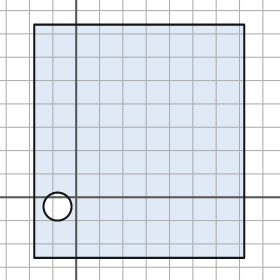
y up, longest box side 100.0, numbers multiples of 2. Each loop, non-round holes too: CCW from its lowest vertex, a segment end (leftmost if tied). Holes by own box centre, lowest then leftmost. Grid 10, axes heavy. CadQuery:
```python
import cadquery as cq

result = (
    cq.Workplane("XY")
    .moveTo(-18.0, -26.0)
    .lineTo(72.0, -26.0)
    .lineTo(72.0, 74.0)
    .lineTo(-18.0, 74.0)
    .close()
    .moveTo(-8.0, -4.0)
    .circle(6.0)
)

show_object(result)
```